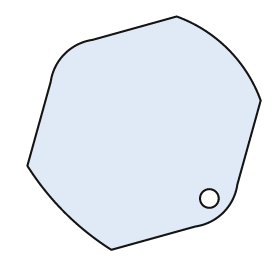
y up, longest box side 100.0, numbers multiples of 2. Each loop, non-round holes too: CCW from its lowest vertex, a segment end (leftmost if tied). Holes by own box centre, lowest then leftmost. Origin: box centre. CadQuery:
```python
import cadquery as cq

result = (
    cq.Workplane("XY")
    .moveTo(-14.0, -50.0)
    .lineTo(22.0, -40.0)
    .threePointArc((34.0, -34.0), (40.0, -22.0))
    .lineTo(50.0, 14.0)
    .threePointArc((36.0, 36.0), (14.0, 50.0))
    .lineTo(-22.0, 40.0)
    .threePointArc((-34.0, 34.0), (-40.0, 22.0))
    .lineTo(-50.0, -14.0)
    .threePointArc((-34.0, -34.0), (-14.0, -50.0))
    .close()
    .moveTo(28.0, -28.0)
    .circle(4.0)
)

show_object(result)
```